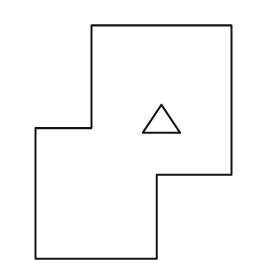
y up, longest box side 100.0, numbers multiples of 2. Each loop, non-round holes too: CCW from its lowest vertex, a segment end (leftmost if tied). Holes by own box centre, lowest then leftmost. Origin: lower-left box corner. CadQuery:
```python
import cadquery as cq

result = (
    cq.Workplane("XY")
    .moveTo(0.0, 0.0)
    .lineTo(52.0, 0.0)
    .lineTo(52.0, 36.0)
    .lineTo(84.0, 36.0)
    .lineTo(84.0, 100.0)
    .lineTo(24.0, 100.0)
    .lineTo(24.0, 56.0)
    .lineTo(0.0, 56.0)
    .close()
    .moveTo(46.0, 54.0)
    .lineTo(62.0, 54.0)
    .lineTo(54.0, 66.0)
    .close()
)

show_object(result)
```